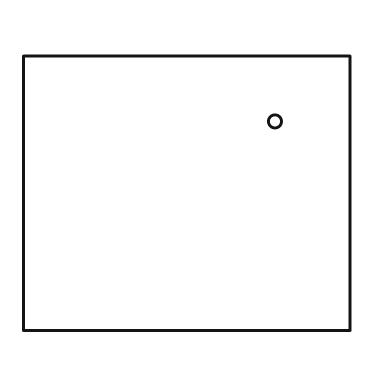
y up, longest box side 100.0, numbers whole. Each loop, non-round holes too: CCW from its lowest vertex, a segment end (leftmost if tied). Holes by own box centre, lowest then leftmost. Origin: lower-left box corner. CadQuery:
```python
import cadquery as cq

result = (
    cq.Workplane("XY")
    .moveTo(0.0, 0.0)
    .lineTo(100.0, 0.0)
    .lineTo(100.0, 84.0)
    .lineTo(0.0, 84.0)
    .close()
    .moveTo(77.0, 64.0)
    .circle(2.0)
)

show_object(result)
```